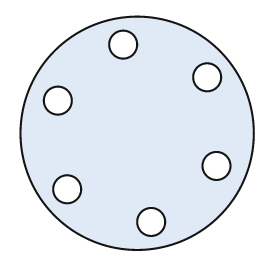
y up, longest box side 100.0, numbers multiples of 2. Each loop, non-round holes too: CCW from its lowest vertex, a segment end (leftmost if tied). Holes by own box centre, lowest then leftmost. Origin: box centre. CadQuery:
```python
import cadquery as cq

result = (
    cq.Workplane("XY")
    .moveTo(0.0, 0.0)
    .circle(50.0)
    .moveTo(6.0, -38.0)
    .circle(6.0)
    .moveTo(-30.0, -24.0)
    .circle(6.0)
    .moveTo(34.0, -14.0)
    .circle(6.0)
    .moveTo(-34.0, 14.0)
    .circle(6.0)
    .moveTo(30.0, 24.0)
    .circle(6.0)
    .moveTo(-6.0, 38.0)
    .circle(6.0)
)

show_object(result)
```